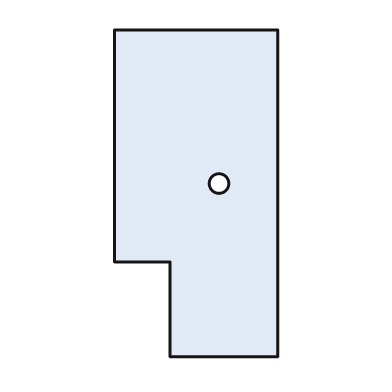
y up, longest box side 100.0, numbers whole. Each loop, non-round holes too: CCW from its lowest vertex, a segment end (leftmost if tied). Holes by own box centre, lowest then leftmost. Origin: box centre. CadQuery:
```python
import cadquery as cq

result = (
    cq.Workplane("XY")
    .moveTo(-8.0, -50.0)
    .lineTo(25.0, -50.0)
    .lineTo(25.0, 50.0)
    .lineTo(-25.0, 50.0)
    .lineTo(-25.0, -21.0)
    .lineTo(-8.0, -21.0)
    .close()
    .moveTo(7.0, 3.0)
    .circle(3.0)
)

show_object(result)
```